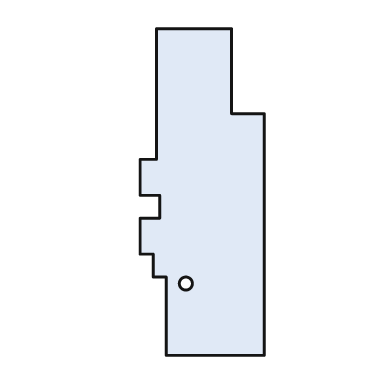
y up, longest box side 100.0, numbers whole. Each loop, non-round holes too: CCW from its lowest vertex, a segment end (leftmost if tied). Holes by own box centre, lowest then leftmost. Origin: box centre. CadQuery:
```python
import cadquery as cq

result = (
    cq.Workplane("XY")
    .moveTo(-11.0, -50.0)
    .lineTo(19.0, -50.0)
    .lineTo(19.0, 24.0)
    .lineTo(9.0, 24.0)
    .lineTo(9.0, 50.0)
    .lineTo(-14.0, 50.0)
    .lineTo(-14.0, 10.0)
    .lineTo(-19.0, 10.0)
    .lineTo(-19.0, -1.0)
    .lineTo(-13.0, -1.0)
    .lineTo(-13.0, -8.0)
    .lineTo(-19.0, -8.0)
    .lineTo(-19.0, -19.0)
    .lineTo(-15.0, -19.0)
    .lineTo(-15.0, -26.0)
    .lineTo(-11.0, -26.0)
    .close()
    .moveTo(-5.0, -28.0)
    .circle(2.0)
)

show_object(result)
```